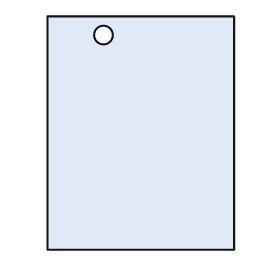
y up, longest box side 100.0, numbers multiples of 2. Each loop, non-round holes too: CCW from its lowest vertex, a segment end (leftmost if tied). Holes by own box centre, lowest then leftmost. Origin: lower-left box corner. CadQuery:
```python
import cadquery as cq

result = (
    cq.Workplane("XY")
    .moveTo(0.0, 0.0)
    .lineTo(80.0, 0.0)
    .lineTo(80.0, 100.0)
    .lineTo(0.0, 100.0)
    .close()
    .moveTo(24.0, 92.0)
    .circle(4.0)
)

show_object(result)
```